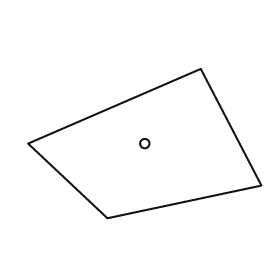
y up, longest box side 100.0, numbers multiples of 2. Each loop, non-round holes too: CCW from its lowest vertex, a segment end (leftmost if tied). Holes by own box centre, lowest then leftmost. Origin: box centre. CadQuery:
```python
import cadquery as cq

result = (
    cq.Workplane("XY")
    .moveTo(-16.0, -32.0)
    .lineTo(50.0, -18.0)
    .lineTo(24.0, 32.0)
    .lineTo(-50.0, 0.0)
    .close()
    .moveTo(0.0, 0.0)
    .circle(2.0)
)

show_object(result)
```